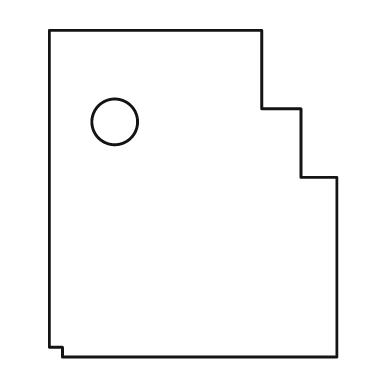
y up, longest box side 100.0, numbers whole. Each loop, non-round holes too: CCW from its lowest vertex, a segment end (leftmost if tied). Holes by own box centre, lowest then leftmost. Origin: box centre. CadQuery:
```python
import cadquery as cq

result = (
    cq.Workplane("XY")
    .moveTo(-40.0, -50.0)
    .lineTo(44.0, -50.0)
    .lineTo(44.0, 5.0)
    .lineTo(33.0, 5.0)
    .lineTo(33.0, 26.0)
    .lineTo(21.0, 26.0)
    .lineTo(21.0, 50.0)
    .lineTo(-44.0, 50.0)
    .lineTo(-44.0, -47.0)
    .lineTo(-40.0, -47.0)
    .close()
    .moveTo(-24.0, 22.0)
    .circle(7.0)
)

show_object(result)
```